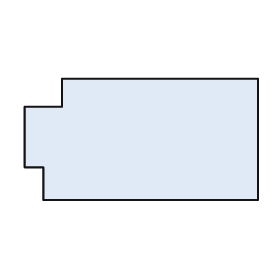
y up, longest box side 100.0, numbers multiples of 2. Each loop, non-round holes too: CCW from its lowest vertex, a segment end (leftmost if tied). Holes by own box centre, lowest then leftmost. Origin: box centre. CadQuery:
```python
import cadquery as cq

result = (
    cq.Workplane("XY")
    .moveTo(-42.0, -26.0)
    .lineTo(50.0, -26.0)
    .lineTo(50.0, 26.0)
    .lineTo(-34.0, 26.0)
    .lineTo(-34.0, 14.0)
    .lineTo(-50.0, 14.0)
    .lineTo(-50.0, -12.0)
    .lineTo(-42.0, -12.0)
    .close()
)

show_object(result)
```